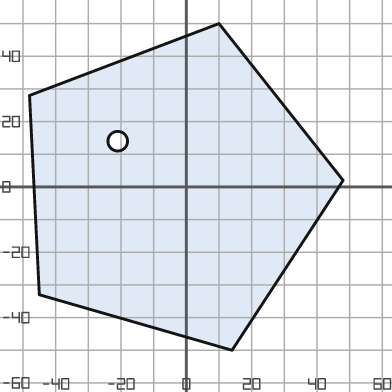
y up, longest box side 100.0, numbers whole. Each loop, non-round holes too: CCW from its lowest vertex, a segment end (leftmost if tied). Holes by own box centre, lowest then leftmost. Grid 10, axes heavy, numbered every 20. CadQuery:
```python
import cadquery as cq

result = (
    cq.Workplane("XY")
    .moveTo(14.0, -50.0)
    .lineTo(48.0, 2.0)
    .lineTo(10.0, 50.0)
    .lineTo(-48.0, 28.0)
    .lineTo(-45.0, -33.0)
    .close()
    .moveTo(-21.0, 14.0)
    .circle(3.0)
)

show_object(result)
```